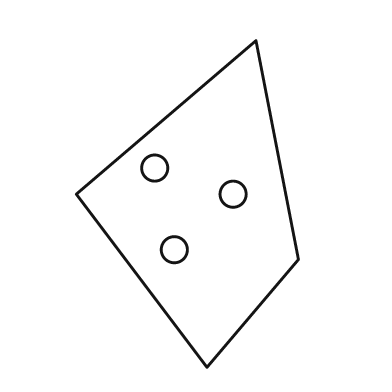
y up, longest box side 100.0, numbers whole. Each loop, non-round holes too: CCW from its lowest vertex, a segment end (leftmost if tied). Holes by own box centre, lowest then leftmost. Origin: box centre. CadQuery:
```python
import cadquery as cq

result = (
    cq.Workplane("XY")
    .moveTo(6.0, -50.0)
    .lineTo(34.0, -17.0)
    .lineTo(21.0, 50.0)
    .lineTo(-34.0, 3.0)
    .close()
    .moveTo(-4.0, -14.0)
    .circle(4.0)
    .moveTo(14.0, 3.0)
    .circle(4.0)
    .moveTo(-10.0, 11.0)
    .circle(4.0)
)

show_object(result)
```